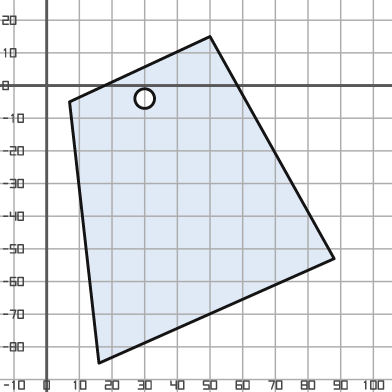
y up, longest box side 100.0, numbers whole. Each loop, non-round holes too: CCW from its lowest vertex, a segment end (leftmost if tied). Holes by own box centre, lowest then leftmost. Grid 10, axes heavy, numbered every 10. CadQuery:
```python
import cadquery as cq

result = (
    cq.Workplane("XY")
    .moveTo(16.0, -85.0)
    .lineTo(88.0, -53.0)
    .lineTo(50.0, 15.0)
    .lineTo(7.0, -5.0)
    .close()
    .moveTo(30.0, -4.0)
    .circle(3.0)
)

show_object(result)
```